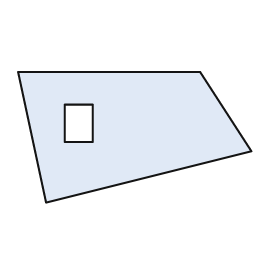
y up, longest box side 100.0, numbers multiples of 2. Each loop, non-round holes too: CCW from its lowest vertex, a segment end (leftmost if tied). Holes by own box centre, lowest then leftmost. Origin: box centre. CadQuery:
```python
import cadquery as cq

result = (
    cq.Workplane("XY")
    .moveTo(-38.0, -28.0)
    .lineTo(50.0, -6.0)
    .lineTo(28.0, 28.0)
    .lineTo(-50.0, 28.0)
    .close()
    .moveTo(-30.0, -2.0)
    .lineTo(-18.0, -2.0)
    .lineTo(-18.0, 14.0)
    .lineTo(-30.0, 14.0)
    .close()
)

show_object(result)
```